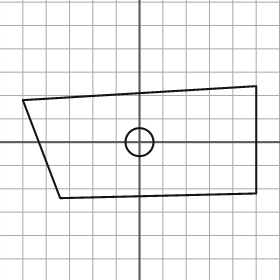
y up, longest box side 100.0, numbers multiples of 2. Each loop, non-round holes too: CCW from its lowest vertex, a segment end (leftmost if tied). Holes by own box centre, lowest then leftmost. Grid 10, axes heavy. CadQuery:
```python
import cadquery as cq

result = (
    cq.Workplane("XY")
    .moveTo(-34.0, -24.0)
    .lineTo(50.0, -22.0)
    .lineTo(50.0, 24.0)
    .lineTo(-50.0, 18.0)
    .close()
    .moveTo(0.0, 0.0)
    .circle(6.0)
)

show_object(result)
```